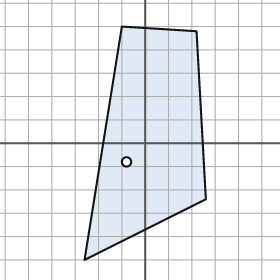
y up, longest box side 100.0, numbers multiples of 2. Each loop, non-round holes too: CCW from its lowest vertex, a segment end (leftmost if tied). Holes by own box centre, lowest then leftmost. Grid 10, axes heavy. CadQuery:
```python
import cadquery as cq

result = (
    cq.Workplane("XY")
    .moveTo(-26.0, -50.0)
    .lineTo(26.0, -24.0)
    .lineTo(22.0, 48.0)
    .lineTo(-10.0, 50.0)
    .close()
    .moveTo(-8.0, -8.0)
    .circle(2.0)
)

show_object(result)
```